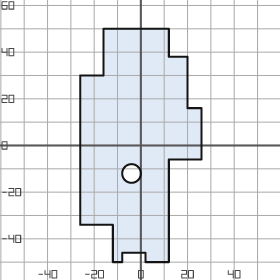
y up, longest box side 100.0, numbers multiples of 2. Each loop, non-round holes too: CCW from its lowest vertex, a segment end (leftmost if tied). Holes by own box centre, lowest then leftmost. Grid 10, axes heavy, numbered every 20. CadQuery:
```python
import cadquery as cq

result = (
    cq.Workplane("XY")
    .moveTo(-12.0, -50.0)
    .lineTo(-8.0, -50.0)
    .lineTo(-8.0, -46.0)
    .lineTo(2.0, -46.0)
    .lineTo(2.0, -50.0)
    .lineTo(12.0, -50.0)
    .lineTo(12.0, -6.0)
    .lineTo(26.0, -6.0)
    .lineTo(26.0, 16.0)
    .lineTo(20.0, 16.0)
    .lineTo(20.0, 38.0)
    .lineTo(12.0, 38.0)
    .lineTo(12.0, 50.0)
    .lineTo(-16.0, 50.0)
    .lineTo(-16.0, 30.0)
    .lineTo(-26.0, 30.0)
    .lineTo(-26.0, -34.0)
    .lineTo(-12.0, -34.0)
    .close()
    .moveTo(-4.0, -12.0)
    .circle(4.0)
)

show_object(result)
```